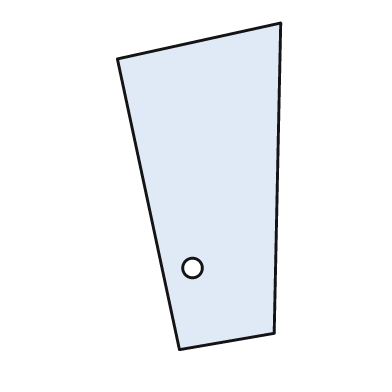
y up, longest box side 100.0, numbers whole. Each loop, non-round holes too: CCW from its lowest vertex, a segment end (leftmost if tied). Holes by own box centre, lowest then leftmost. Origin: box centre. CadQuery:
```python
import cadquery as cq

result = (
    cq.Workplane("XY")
    .moveTo(-6.0, -50.0)
    .lineTo(23.0, -45.0)
    .lineTo(25.0, 50.0)
    .lineTo(-25.0, 39.0)
    .close()
    .moveTo(-2.0, -25.0)
    .circle(3.0)
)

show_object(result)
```